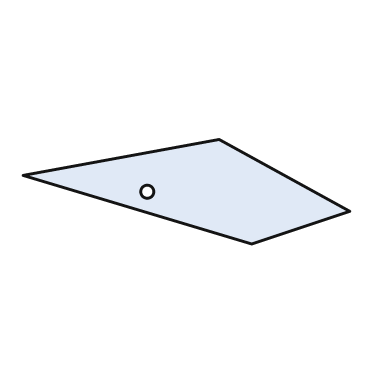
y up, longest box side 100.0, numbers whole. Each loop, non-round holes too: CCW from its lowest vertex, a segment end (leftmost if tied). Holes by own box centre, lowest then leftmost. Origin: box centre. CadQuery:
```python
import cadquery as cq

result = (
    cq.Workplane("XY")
    .moveTo(20.0, -16.0)
    .lineTo(50.0, -6.0)
    .lineTo(10.0, 16.0)
    .lineTo(-50.0, 5.0)
    .close()
    .moveTo(-12.0, 0.0)
    .circle(2.0)
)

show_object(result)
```